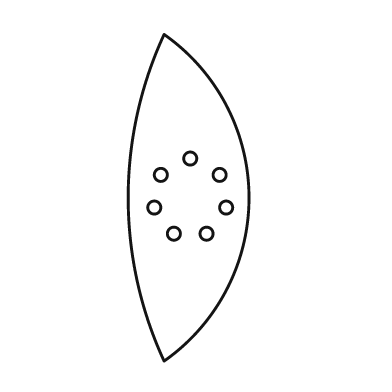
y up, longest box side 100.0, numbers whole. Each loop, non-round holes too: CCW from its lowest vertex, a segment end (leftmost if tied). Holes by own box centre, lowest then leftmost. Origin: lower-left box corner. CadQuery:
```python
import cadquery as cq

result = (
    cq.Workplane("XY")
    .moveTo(11.0, 0.0)
    .threePointArc((37.0, 50.0), (11.0, 100.0))
    .threePointArc((0.0, 50.0), (11.0, 0.0))
    .close()
    .moveTo(14.0, 39.0)
    .circle(2.0)
    .moveTo(24.0, 39.0)
    .circle(2.0)
    .moveTo(8.0, 47.0)
    .circle(2.0)
    .moveTo(30.0, 47.0)
    .circle(2.0)
    .moveTo(10.0, 57.0)
    .circle(2.0)
    .moveTo(28.0, 57.0)
    .circle(2.0)
    .moveTo(19.0, 62.0)
    .circle(2.0)
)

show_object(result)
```